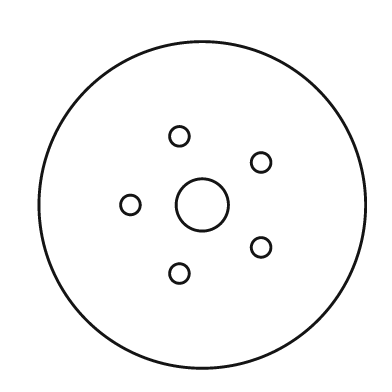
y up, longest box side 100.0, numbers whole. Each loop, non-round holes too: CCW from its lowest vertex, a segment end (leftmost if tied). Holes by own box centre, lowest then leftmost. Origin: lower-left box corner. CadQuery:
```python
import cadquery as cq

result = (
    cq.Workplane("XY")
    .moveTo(50.0, 50.0)
    .circle(50.0)
    .moveTo(43.0, 29.0)
    .circle(3.0)
    .moveTo(68.0, 37.0)
    .circle(3.0)
    .moveTo(28.0, 50.0)
    .circle(3.0)
    .moveTo(50.0, 50.0)
    .circle(8.0)
    .moveTo(68.0, 63.0)
    .circle(3.0)
    .moveTo(43.0, 71.0)
    .circle(3.0)
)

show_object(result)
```